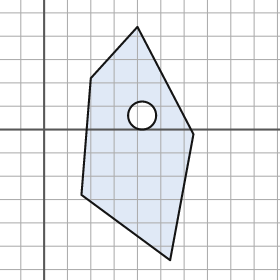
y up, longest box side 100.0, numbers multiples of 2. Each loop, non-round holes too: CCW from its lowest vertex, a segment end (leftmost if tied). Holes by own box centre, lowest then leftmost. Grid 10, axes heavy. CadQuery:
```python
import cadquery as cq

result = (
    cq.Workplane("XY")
    .moveTo(54.0, -56.0)
    .lineTo(64.0, -2.0)
    .lineTo(40.0, 44.0)
    .lineTo(20.0, 22.0)
    .lineTo(16.0, -28.0)
    .close()
    .moveTo(42.0, 6.0)
    .circle(6.0)
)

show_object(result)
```